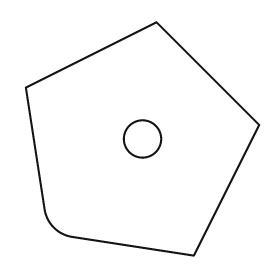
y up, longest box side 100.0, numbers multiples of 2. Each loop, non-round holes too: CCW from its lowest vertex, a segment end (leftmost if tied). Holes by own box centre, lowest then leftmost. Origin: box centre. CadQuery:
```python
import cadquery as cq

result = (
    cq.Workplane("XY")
    .moveTo(22.0, -50.0)
    .lineTo(50.0, 6.0)
    .lineTo(6.0, 50.0)
    .lineTo(-50.0, 22.0)
    .lineTo(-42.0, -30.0)
    .threePointArc((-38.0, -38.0), (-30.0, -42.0))
    .close()
    .moveTo(0.0, 0.0)
    .circle(8.0)
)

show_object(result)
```